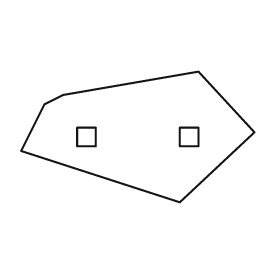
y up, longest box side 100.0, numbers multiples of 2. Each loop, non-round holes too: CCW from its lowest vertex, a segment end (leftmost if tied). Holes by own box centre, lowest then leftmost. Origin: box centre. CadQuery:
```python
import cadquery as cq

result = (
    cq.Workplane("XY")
    .moveTo(18.0, -28.0)
    .lineTo(50.0, 2.0)
    .lineTo(26.0, 28.0)
    .lineTo(-32.0, 18.0)
    .lineTo(-40.0, 14.0)
    .lineTo(-50.0, -6.0)
    .close()
    .moveTo(-26.0, -4.0)
    .lineTo(-18.0, -4.0)
    .lineTo(-18.0, 4.0)
    .lineTo(-26.0, 4.0)
    .close()
    .moveTo(18.0, -4.0)
    .lineTo(26.0, -4.0)
    .lineTo(26.0, 4.0)
    .lineTo(18.0, 4.0)
    .close()
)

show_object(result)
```